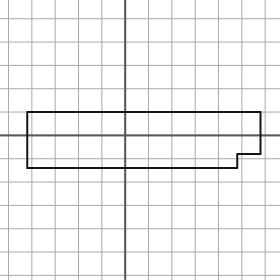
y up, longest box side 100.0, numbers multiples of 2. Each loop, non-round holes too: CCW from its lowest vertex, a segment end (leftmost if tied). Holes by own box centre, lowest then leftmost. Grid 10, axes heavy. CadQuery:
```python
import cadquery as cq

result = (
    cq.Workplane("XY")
    .moveTo(-42.0, -14.0)
    .lineTo(48.0, -14.0)
    .lineTo(48.0, -8.0)
    .lineTo(58.0, -8.0)
    .lineTo(58.0, 10.0)
    .lineTo(-42.0, 10.0)
    .close()
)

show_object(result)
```